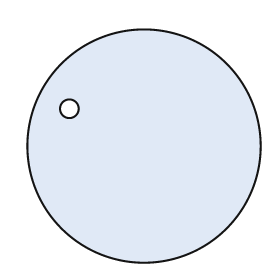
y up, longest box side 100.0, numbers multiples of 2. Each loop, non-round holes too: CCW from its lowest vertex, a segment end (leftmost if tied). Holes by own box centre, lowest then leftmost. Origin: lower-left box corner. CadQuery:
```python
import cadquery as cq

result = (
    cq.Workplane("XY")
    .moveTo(50.0, 50.0)
    .circle(50.0)
    .moveTo(18.0, 66.0)
    .circle(4.0)
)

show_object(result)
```